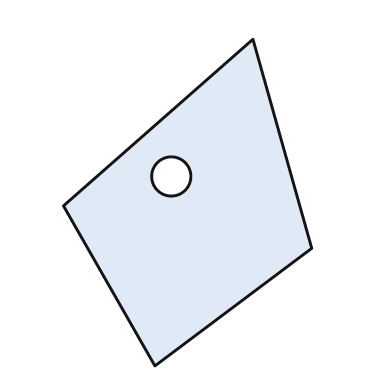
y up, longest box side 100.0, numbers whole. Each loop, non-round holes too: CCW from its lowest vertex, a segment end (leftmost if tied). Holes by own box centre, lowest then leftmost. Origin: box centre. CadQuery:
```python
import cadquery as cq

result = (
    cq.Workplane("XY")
    .moveTo(-10.0, -50.0)
    .lineTo(38.0, -14.0)
    .lineTo(20.0, 50.0)
    .lineTo(-38.0, -1.0)
    .close()
    .moveTo(-5.0, 8.0)
    .circle(6.0)
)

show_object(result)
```